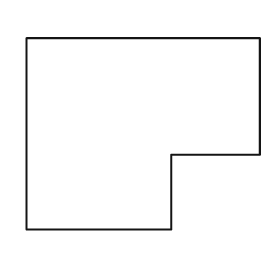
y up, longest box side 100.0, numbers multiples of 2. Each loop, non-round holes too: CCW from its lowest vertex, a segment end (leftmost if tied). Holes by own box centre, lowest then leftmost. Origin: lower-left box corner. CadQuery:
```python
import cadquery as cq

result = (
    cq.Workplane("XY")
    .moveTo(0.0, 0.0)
    .lineTo(62.0, 0.0)
    .lineTo(62.0, 32.0)
    .lineTo(100.0, 32.0)
    .lineTo(100.0, 82.0)
    .lineTo(0.0, 82.0)
    .close()
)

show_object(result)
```